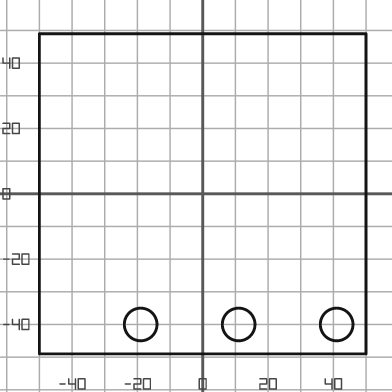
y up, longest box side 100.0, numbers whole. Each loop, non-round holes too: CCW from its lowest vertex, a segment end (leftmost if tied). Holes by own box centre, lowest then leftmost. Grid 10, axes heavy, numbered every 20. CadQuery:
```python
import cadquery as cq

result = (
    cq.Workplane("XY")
    .moveTo(-50.0, -49.0)
    .lineTo(50.0, -49.0)
    .lineTo(50.0, 49.0)
    .lineTo(-50.0, 49.0)
    .close()
    .moveTo(-19.0, -40.0)
    .circle(5.0)
    .moveTo(11.0, -40.0)
    .circle(5.0)
    .moveTo(41.0, -40.0)
    .circle(5.0)
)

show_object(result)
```